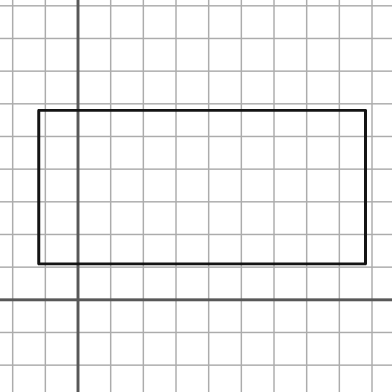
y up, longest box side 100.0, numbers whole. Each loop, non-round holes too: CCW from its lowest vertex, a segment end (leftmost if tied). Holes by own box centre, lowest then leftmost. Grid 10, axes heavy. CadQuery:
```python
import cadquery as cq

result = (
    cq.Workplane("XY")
    .moveTo(-12.0, 11.0)
    .lineTo(88.0, 11.0)
    .lineTo(88.0, 58.0)
    .lineTo(-12.0, 58.0)
    .close()
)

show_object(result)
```